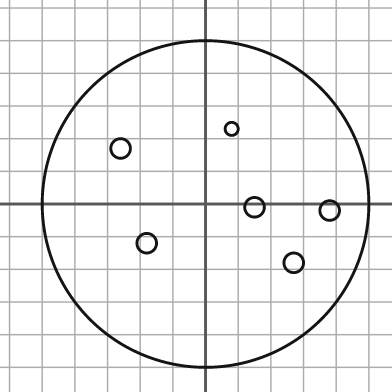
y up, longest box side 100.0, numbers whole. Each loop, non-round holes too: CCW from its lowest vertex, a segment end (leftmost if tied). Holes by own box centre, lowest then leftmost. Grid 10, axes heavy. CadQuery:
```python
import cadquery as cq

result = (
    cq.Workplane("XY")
    .moveTo(0.0, 0.0)
    .circle(50.0)
    .moveTo(27.0, -18.0)
    .circle(3.0)
    .moveTo(-18.0, -12.0)
    .circle(3.0)
    .moveTo(38.0, -2.0)
    .circle(3.0)
    .moveTo(15.0, -1.0)
    .circle(3.0)
    .moveTo(-26.0, 17.0)
    .circle(3.0)
    .moveTo(8.0, 23.0)
    .circle(2.0)
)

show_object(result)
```